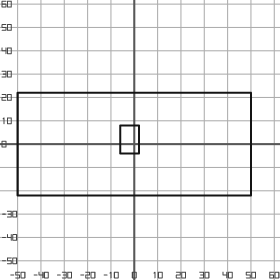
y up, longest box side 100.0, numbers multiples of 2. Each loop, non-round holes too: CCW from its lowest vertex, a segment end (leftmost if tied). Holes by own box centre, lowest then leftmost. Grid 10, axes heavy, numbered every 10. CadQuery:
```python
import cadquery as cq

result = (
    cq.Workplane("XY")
    .moveTo(-50.0, -22.0)
    .lineTo(50.0, -22.0)
    .lineTo(50.0, 22.0)
    .lineTo(-50.0, 22.0)
    .close()
    .moveTo(-6.0, -4.0)
    .lineTo(2.0, -4.0)
    .lineTo(2.0, 8.0)
    .lineTo(-6.0, 8.0)
    .close()
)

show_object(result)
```